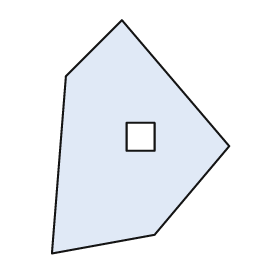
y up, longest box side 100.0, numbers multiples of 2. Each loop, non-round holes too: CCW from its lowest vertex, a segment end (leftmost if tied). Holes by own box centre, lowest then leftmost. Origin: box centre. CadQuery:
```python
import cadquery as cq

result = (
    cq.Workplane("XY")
    .moveTo(-38.0, -50.0)
    .lineTo(6.0, -42.0)
    .lineTo(38.0, -4.0)
    .lineTo(-8.0, 50.0)
    .lineTo(-32.0, 26.0)
    .close()
    .moveTo(-6.0, -6.0)
    .lineTo(6.0, -6.0)
    .lineTo(6.0, 6.0)
    .lineTo(-6.0, 6.0)
    .close()
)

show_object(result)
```